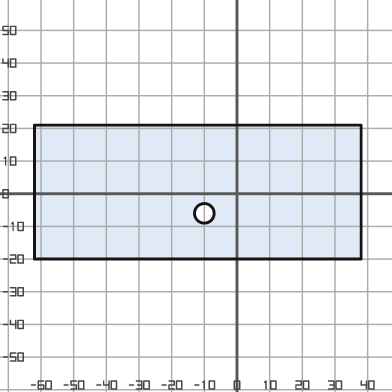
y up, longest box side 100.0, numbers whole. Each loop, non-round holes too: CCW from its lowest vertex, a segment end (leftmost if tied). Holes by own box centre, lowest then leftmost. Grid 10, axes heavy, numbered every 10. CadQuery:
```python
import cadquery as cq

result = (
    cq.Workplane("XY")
    .moveTo(-62.0, -20.0)
    .lineTo(38.0, -20.0)
    .lineTo(38.0, 21.0)
    .lineTo(-62.0, 21.0)
    .close()
    .moveTo(-10.0, -6.0)
    .circle(3.0)
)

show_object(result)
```